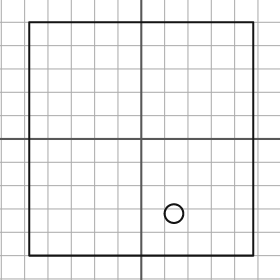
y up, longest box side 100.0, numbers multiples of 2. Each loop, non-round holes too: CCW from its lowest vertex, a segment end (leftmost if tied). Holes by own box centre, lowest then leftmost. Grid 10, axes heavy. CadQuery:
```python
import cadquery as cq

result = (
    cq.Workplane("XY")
    .moveTo(-48.0, -50.0)
    .lineTo(48.0, -50.0)
    .lineTo(48.0, 50.0)
    .lineTo(-48.0, 50.0)
    .close()
    .moveTo(14.0, -32.0)
    .circle(4.0)
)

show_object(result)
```